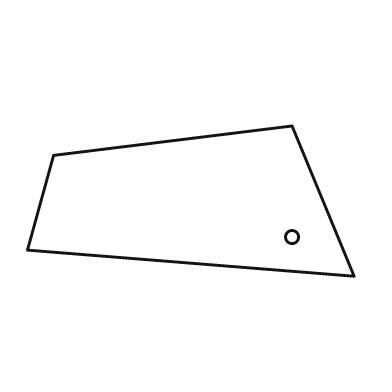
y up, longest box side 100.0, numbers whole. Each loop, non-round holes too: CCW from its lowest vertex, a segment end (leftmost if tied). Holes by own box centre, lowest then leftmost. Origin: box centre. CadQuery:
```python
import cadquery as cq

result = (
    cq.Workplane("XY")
    .moveTo(50.0, -23.0)
    .lineTo(31.0, 23.0)
    .lineTo(-42.0, 14.0)
    .lineTo(-50.0, -15.0)
    .close()
    .moveTo(31.0, -11.0)
    .circle(2.0)
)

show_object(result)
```